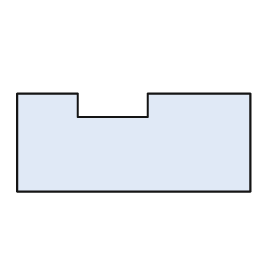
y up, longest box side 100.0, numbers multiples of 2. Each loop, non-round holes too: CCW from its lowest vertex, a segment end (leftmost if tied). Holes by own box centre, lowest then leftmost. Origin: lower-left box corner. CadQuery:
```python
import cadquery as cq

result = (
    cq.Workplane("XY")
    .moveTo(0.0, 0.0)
    .lineTo(100.0, 0.0)
    .lineTo(100.0, 42.0)
    .lineTo(56.0, 42.0)
    .lineTo(56.0, 32.0)
    .lineTo(26.0, 32.0)
    .lineTo(26.0, 42.0)
    .lineTo(0.0, 42.0)
    .close()
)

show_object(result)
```